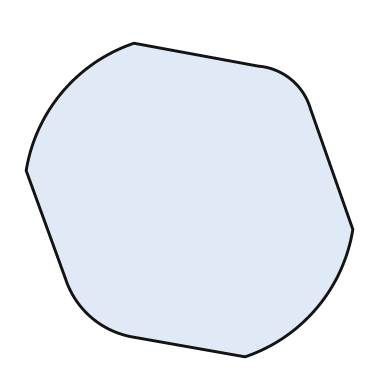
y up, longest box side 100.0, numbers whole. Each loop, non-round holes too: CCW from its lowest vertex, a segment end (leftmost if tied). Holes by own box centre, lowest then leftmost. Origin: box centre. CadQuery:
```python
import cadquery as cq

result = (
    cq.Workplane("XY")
    .moveTo(17.0, -48.0)
    .threePointArc((39.0, -33.0), (50.0, -9.0))
    .lineTo(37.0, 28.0)
    .threePointArc((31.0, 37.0), (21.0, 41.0))
    .lineTo(-17.0, 48.0)
    .threePointArc((-39.0, 33.0), (-50.0, 9.0))
    .lineTo(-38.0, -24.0)
    .threePointArc((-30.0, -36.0), (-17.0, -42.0))
    .close()
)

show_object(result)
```